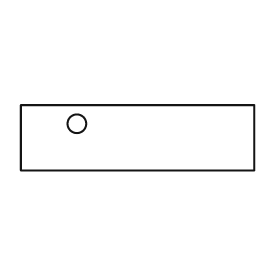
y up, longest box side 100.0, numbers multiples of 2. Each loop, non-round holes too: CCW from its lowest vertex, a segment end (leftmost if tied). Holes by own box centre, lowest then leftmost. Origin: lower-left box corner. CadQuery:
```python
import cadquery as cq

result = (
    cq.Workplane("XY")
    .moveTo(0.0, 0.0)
    .lineTo(100.0, 0.0)
    .lineTo(100.0, 28.0)
    .lineTo(0.0, 28.0)
    .close()
    .moveTo(24.0, 20.0)
    .circle(4.0)
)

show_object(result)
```